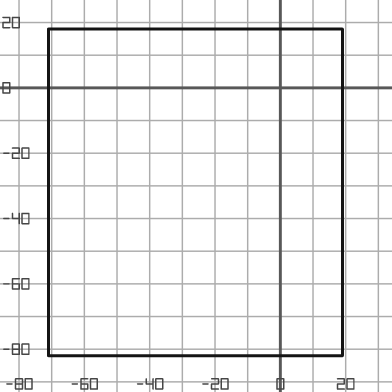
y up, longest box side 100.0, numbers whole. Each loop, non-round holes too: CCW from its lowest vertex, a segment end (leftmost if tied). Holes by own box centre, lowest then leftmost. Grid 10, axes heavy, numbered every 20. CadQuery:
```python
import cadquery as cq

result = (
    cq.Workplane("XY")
    .moveTo(-71.0, -82.0)
    .lineTo(19.0, -82.0)
    .lineTo(19.0, 18.0)
    .lineTo(-71.0, 18.0)
    .close()
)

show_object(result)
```